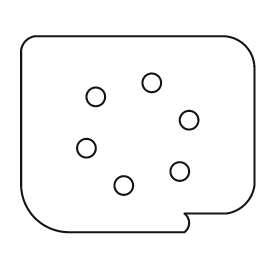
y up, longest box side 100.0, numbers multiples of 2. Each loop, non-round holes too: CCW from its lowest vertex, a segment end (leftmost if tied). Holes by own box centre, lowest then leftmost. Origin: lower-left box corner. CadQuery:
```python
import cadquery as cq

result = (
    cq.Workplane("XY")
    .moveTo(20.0, 0.0)
    .lineTo(70.0, 0.0)
    .threePointArc((72.0, 4.0), (70.0, 8.0))
    .lineTo(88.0, 8.0)
    .threePointArc((96.0, 12.0), (100.0, 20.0))
    .lineTo(100.0, 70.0)
    .threePointArc((96.0, 80.0), (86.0, 84.0))
    .lineTo(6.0, 84.0)
    .threePointArc((2.0, 82.0), (0.0, 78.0))
    .lineTo(0.0, 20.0)
    .threePointArc((6.0, 6.0), (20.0, 0.0))
    .close()
    .moveTo(44.0, 20.0)
    .circle(4.0)
    .moveTo(68.0, 26.0)
    .circle(4.0)
    .moveTo(28.0, 36.0)
    .circle(4.0)
    .moveTo(72.0, 48.0)
    .circle(4.0)
    .moveTo(32.0, 58.0)
    .circle(4.0)
    .moveTo(56.0, 64.0)
    .circle(4.0)
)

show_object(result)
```